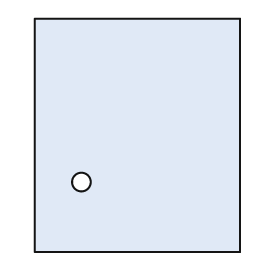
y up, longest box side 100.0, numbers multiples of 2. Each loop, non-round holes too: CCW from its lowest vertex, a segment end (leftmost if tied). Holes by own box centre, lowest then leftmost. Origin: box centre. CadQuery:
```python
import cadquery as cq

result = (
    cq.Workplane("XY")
    .moveTo(-44.0, -50.0)
    .lineTo(44.0, -50.0)
    .lineTo(44.0, 50.0)
    .lineTo(-44.0, 50.0)
    .close()
    .moveTo(-24.0, -20.0)
    .circle(4.0)
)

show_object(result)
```